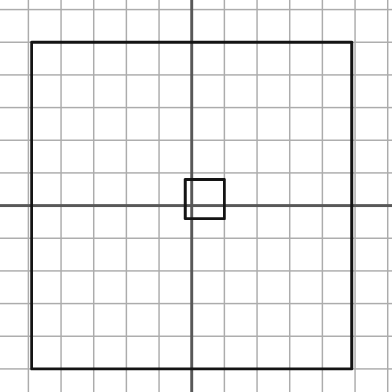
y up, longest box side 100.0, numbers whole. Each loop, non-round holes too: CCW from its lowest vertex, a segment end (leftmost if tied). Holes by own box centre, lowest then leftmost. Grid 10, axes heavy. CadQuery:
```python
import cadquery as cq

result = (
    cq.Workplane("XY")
    .moveTo(-49.0, -50.0)
    .lineTo(49.0, -50.0)
    .lineTo(49.0, 50.0)
    .lineTo(-49.0, 50.0)
    .close()
    .moveTo(-2.0, -4.0)
    .lineTo(10.0, -4.0)
    .lineTo(10.0, 8.0)
    .lineTo(-2.0, 8.0)
    .close()
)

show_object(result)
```